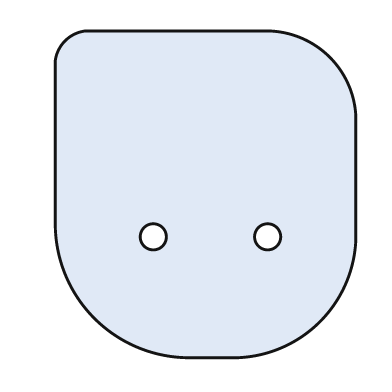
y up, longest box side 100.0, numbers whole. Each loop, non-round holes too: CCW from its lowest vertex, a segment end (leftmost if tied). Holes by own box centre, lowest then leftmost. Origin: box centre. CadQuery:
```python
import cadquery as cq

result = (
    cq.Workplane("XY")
    .moveTo(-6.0, -50.0)
    .lineTo(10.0, -50.0)
    .threePointArc((35.0, -39.0), (46.0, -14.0))
    .lineTo(46.0, 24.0)
    .threePointArc((38.0, 42.0), (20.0, 50.0))
    .lineTo(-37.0, 50.0)
    .threePointArc((-43.0, 47.0), (-46.0, 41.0))
    .lineTo(-46.0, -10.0)
    .threePointArc((-34.0, -38.0), (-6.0, -50.0))
    .close()
    .moveTo(-16.0, -13.0)
    .circle(4.0)
    .moveTo(19.0, -13.0)
    .circle(4.0)
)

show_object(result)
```